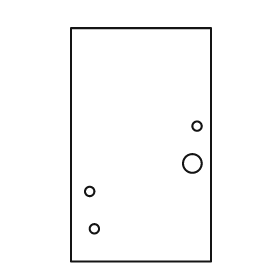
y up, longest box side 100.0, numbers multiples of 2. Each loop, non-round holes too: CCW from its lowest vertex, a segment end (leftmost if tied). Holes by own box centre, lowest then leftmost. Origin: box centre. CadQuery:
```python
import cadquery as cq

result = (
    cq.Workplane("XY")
    .moveTo(-30.0, -50.0)
    .lineTo(30.0, -50.0)
    .lineTo(30.0, 50.0)
    .lineTo(-30.0, 50.0)
    .close()
    .moveTo(-20.0, -36.0)
    .circle(2.0)
    .moveTo(-22.0, -20.0)
    .circle(2.0)
    .moveTo(22.0, -8.0)
    .circle(4.0)
    .moveTo(24.0, 8.0)
    .circle(2.0)
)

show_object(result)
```